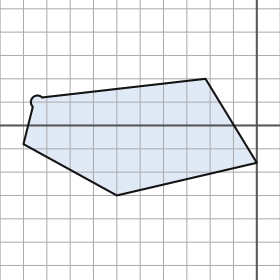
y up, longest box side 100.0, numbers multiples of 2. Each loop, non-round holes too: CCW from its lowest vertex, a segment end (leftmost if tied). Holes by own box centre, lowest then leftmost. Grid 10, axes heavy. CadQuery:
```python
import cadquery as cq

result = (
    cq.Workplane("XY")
    .moveTo(-60.0, -30.0)
    .lineTo(0.0, -16.0)
    .lineTo(-22.0, 20.0)
    .lineTo(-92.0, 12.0)
    .threePointArc((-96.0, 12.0), (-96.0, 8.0))
    .lineTo(-100.0, -8.0)
    .close()
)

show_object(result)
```